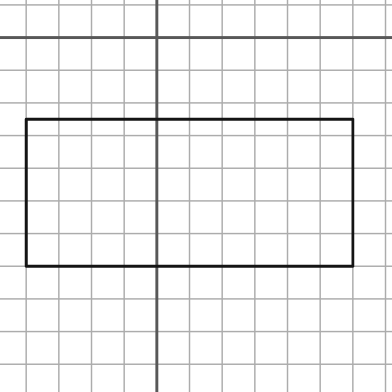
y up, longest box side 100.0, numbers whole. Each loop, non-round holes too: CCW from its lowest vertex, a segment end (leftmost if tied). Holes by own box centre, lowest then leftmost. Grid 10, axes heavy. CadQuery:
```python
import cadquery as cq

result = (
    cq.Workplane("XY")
    .moveTo(-40.0, -70.0)
    .lineTo(60.0, -70.0)
    .lineTo(60.0, -25.0)
    .lineTo(-40.0, -25.0)
    .close()
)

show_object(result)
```